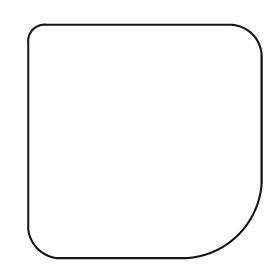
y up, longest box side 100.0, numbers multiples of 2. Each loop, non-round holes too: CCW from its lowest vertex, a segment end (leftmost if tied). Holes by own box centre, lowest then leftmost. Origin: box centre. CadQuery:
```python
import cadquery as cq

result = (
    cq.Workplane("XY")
    .moveTo(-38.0, -50.0)
    .lineTo(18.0, -50.0)
    .threePointArc((40.0, -40.0), (50.0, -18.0))
    .lineTo(50.0, 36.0)
    .threePointArc((46.0, 46.0), (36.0, 50.0))
    .lineTo(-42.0, 50.0)
    .threePointArc((-48.0, 48.0), (-50.0, 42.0))
    .lineTo(-50.0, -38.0)
    .threePointArc((-46.0, -46.0), (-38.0, -50.0))
    .close()
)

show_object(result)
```